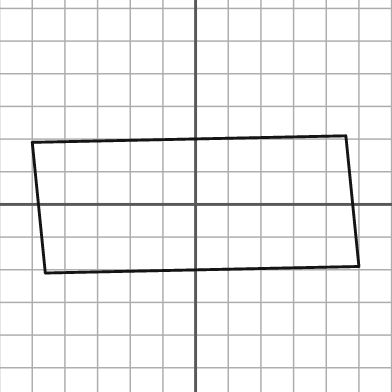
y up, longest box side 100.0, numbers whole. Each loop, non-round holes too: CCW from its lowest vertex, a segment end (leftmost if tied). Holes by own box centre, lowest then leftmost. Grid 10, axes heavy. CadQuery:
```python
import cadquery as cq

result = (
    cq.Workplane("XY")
    .moveTo(-46.0, -21.0)
    .lineTo(50.0, -19.0)
    .lineTo(46.0, 21.0)
    .lineTo(-50.0, 19.0)
    .close()
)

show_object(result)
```